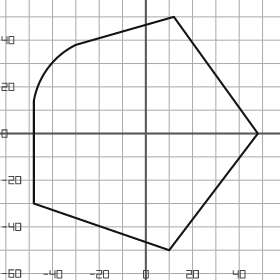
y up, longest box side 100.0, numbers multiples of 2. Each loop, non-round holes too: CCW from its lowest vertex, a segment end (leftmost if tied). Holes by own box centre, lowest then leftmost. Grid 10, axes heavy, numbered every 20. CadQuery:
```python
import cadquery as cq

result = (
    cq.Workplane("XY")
    .moveTo(10.0, -50.0)
    .lineTo(48.0, 0.0)
    .lineTo(12.0, 50.0)
    .lineTo(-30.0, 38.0)
    .threePointArc((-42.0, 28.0), (-48.0, 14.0))
    .lineTo(-48.0, -30.0)
    .close()
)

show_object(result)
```